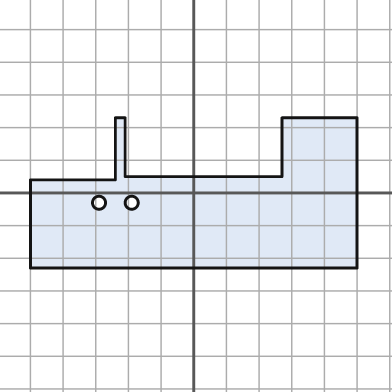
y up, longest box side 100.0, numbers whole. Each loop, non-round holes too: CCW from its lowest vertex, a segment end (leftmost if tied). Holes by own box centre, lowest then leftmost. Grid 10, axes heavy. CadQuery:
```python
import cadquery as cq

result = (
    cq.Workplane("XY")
    .moveTo(-50.0, -23.0)
    .lineTo(50.0, -23.0)
    .lineTo(50.0, 23.0)
    .lineTo(27.0, 23.0)
    .lineTo(27.0, 5.0)
    .lineTo(-21.0, 5.0)
    .lineTo(-21.0, 23.0)
    .lineTo(-24.0, 23.0)
    .lineTo(-24.0, 4.0)
    .lineTo(-50.0, 4.0)
    .close()
    .moveTo(-29.0, -3.0)
    .circle(2.0)
    .moveTo(-19.0, -3.0)
    .circle(2.0)
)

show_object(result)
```